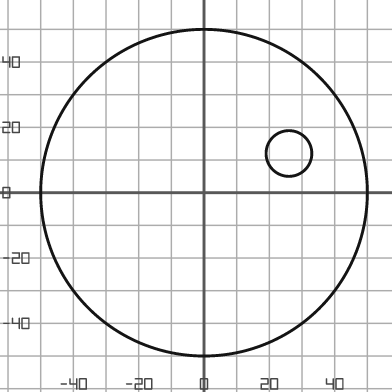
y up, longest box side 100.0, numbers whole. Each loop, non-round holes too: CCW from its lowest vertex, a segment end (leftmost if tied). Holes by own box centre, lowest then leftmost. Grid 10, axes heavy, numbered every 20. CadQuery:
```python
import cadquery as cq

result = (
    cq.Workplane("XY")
    .moveTo(0.0, 0.0)
    .circle(50.0)
    .moveTo(26.0, 12.0)
    .circle(7.0)
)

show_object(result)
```